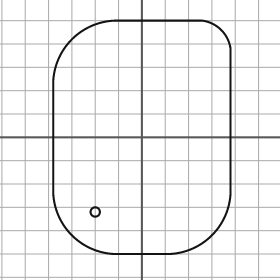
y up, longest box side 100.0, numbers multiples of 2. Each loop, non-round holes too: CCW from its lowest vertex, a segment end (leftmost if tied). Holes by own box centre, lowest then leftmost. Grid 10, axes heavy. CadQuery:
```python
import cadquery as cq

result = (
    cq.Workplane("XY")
    .moveTo(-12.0, -50.0)
    .lineTo(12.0, -50.0)
    .threePointArc((30.0, -42.0), (38.0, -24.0))
    .lineTo(38.0, 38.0)
    .threePointArc((34.0, 46.0), (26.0, 50.0))
    .lineTo(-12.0, 50.0)
    .threePointArc((-30.0, 42.0), (-38.0, 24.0))
    .lineTo(-38.0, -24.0)
    .threePointArc((-30.0, -42.0), (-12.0, -50.0))
    .close()
    .moveTo(-20.0, -32.0)
    .circle(2.0)
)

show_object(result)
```